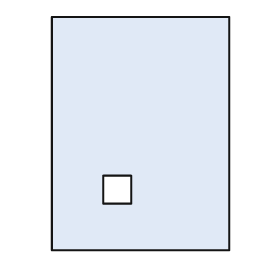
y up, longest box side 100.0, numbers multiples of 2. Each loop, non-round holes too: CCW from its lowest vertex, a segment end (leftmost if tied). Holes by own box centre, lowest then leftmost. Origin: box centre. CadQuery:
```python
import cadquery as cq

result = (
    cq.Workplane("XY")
    .moveTo(-38.0, -50.0)
    .lineTo(38.0, -50.0)
    .lineTo(38.0, 50.0)
    .lineTo(-38.0, 50.0)
    .close()
    .moveTo(-16.0, -30.0)
    .lineTo(-4.0, -30.0)
    .lineTo(-4.0, -18.0)
    .lineTo(-16.0, -18.0)
    .close()
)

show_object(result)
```